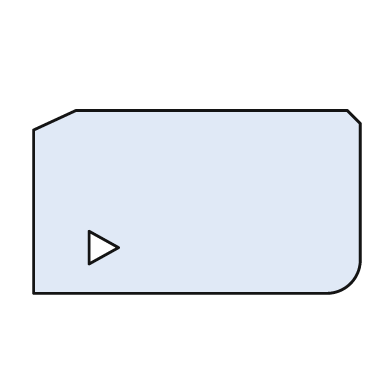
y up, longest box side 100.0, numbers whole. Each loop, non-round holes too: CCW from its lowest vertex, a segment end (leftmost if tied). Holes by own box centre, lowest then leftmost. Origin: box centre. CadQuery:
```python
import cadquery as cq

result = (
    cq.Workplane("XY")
    .moveTo(-50.0, -28.0)
    .lineTo(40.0, -28.0)
    .threePointArc((47.0, -25.0), (50.0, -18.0))
    .lineTo(50.0, 24.0)
    .lineTo(46.0, 28.0)
    .lineTo(-37.0, 28.0)
    .lineTo(-50.0, 22.0)
    .close()
    .moveTo(-33.0, -19.0)
    .lineTo(-24.0, -14.0)
    .lineTo(-33.0, -9.0)
    .close()
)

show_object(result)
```